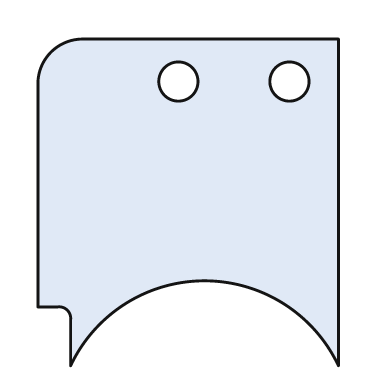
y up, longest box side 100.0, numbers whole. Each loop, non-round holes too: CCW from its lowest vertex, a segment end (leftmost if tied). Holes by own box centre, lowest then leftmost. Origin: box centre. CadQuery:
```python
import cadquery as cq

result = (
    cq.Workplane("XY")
    .moveTo(-36.0, -50.0)
    .threePointArc((5.0, -24.0), (46.0, -50.0))
    .lineTo(46.0, 50.0)
    .lineTo(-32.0, 50.0)
    .threePointArc((-42.0, 46.0), (-46.0, 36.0))
    .lineTo(-46.0, -32.0)
    .lineTo(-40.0, -32.0)
    .threePointArc((-37.0, -33.0), (-36.0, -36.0))
    .close()
    .moveTo(-3.0, 37.0)
    .circle(6.0)
    .moveTo(31.0, 37.0)
    .circle(6.0)
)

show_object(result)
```